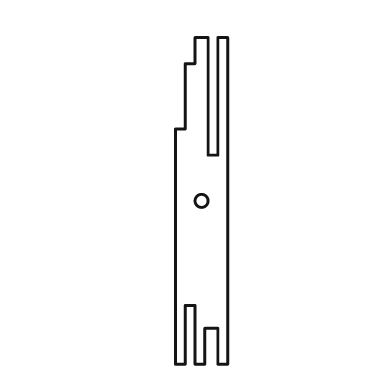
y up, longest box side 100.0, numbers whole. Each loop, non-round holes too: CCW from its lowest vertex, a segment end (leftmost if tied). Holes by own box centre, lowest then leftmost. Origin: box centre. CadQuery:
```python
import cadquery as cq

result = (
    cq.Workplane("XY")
    .moveTo(-8.0, -50.0)
    .lineTo(-5.0, -50.0)
    .lineTo(-5.0, -32.0)
    .lineTo(-2.0, -32.0)
    .lineTo(-2.0, -50.0)
    .lineTo(1.0, -50.0)
    .lineTo(1.0, -39.0)
    .lineTo(5.0, -39.0)
    .lineTo(5.0, -50.0)
    .lineTo(8.0, -50.0)
    .lineTo(8.0, 50.0)
    .lineTo(5.0, 50.0)
    .lineTo(5.0, 14.0)
    .lineTo(2.0, 14.0)
    .lineTo(2.0, 50.0)
    .lineTo(-2.0, 50.0)
    .lineTo(-2.0, 42.0)
    .lineTo(-5.0, 42.0)
    .lineTo(-5.0, 22.0)
    .lineTo(-8.0, 22.0)
    .close()
    .moveTo(0.0, 0.0)
    .circle(2.0)
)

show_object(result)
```